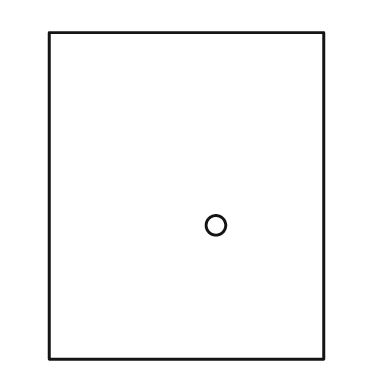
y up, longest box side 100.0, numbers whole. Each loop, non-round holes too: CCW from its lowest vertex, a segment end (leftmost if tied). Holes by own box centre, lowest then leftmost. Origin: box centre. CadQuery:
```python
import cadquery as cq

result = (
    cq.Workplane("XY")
    .moveTo(-42.0, -50.0)
    .lineTo(42.0, -50.0)
    .lineTo(42.0, 50.0)
    .lineTo(-42.0, 50.0)
    .close()
    .moveTo(9.0, -9.0)
    .circle(3.0)
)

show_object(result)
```